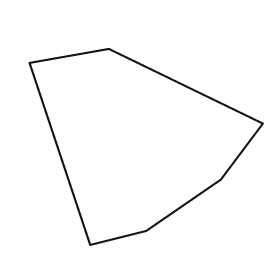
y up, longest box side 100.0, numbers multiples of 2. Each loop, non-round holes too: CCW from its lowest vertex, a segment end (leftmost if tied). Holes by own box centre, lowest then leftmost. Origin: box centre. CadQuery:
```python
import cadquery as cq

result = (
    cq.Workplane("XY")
    .moveTo(-24.0, -42.0)
    .lineTo(0.0, -36.0)
    .lineTo(32.0, -14.0)
    .lineTo(50.0, 10.0)
    .lineTo(-16.0, 42.0)
    .lineTo(-50.0, 36.0)
    .close()
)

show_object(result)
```